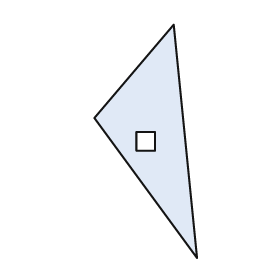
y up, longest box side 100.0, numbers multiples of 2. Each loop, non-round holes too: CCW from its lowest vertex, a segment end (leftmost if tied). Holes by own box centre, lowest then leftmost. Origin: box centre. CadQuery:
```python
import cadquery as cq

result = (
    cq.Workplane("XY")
    .moveTo(22.0, -50.0)
    .lineTo(12.0, 50.0)
    .lineTo(-22.0, 10.0)
    .close()
    .moveTo(-4.0, -4.0)
    .lineTo(4.0, -4.0)
    .lineTo(4.0, 4.0)
    .lineTo(-4.0, 4.0)
    .close()
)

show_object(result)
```